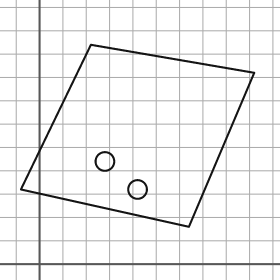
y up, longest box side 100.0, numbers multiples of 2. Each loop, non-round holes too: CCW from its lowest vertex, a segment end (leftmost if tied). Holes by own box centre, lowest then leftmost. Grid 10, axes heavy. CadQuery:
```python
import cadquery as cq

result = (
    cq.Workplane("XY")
    .moveTo(64.0, 16.0)
    .lineTo(92.0, 82.0)
    .lineTo(22.0, 94.0)
    .lineTo(-8.0, 32.0)
    .close()
    .moveTo(42.0, 32.0)
    .circle(4.0)
    .moveTo(28.0, 44.0)
    .circle(4.0)
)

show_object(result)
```